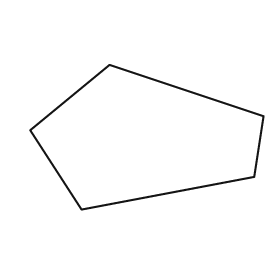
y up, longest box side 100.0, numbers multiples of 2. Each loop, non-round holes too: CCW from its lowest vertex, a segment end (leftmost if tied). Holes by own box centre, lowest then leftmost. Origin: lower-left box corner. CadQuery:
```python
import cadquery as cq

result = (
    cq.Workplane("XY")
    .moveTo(22.0, 0.0)
    .lineTo(96.0, 14.0)
    .lineTo(100.0, 40.0)
    .lineTo(34.0, 62.0)
    .lineTo(0.0, 34.0)
    .close()
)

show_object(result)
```